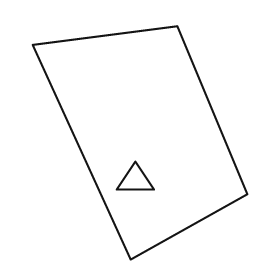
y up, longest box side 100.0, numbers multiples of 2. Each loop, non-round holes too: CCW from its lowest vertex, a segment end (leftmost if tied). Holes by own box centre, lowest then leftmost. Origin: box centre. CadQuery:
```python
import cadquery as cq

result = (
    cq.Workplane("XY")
    .moveTo(-4.0, -50.0)
    .lineTo(46.0, -22.0)
    .lineTo(16.0, 50.0)
    .lineTo(-46.0, 42.0)
    .close()
    .moveTo(-10.0, -20.0)
    .lineTo(6.0, -20.0)
    .lineTo(-2.0, -8.0)
    .close()
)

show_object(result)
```